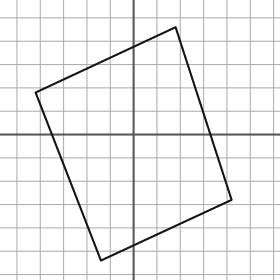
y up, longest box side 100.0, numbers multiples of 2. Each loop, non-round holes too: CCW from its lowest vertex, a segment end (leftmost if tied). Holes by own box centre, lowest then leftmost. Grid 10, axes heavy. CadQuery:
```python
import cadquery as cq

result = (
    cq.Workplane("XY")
    .moveTo(-14.0, -54.0)
    .lineTo(42.0, -28.0)
    .lineTo(18.0, 46.0)
    .lineTo(-42.0, 18.0)
    .close()
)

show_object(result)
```